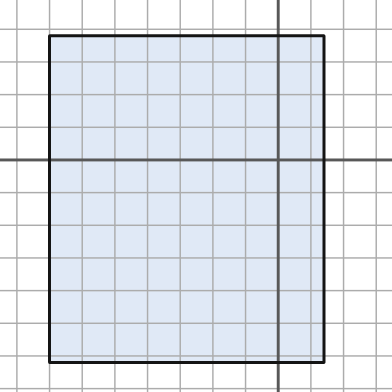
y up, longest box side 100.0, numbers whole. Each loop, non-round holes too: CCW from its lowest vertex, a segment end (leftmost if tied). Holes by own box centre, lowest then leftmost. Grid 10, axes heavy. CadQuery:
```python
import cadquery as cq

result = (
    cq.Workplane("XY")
    .moveTo(-70.0, -62.0)
    .lineTo(14.0, -62.0)
    .lineTo(14.0, 38.0)
    .lineTo(-70.0, 38.0)
    .close()
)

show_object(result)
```